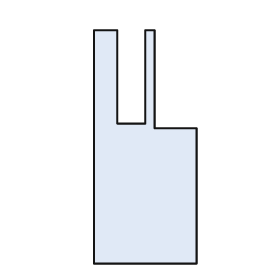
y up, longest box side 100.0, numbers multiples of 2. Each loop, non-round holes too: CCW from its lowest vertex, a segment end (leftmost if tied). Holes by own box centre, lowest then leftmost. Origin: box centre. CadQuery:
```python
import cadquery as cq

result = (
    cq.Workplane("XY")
    .moveTo(-22.0, -50.0)
    .lineTo(22.0, -50.0)
    .lineTo(22.0, 8.0)
    .lineTo(4.0, 8.0)
    .lineTo(4.0, 50.0)
    .lineTo(0.0, 50.0)
    .lineTo(0.0, 10.0)
    .lineTo(-12.0, 10.0)
    .lineTo(-12.0, 50.0)
    .lineTo(-22.0, 50.0)
    .close()
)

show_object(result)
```